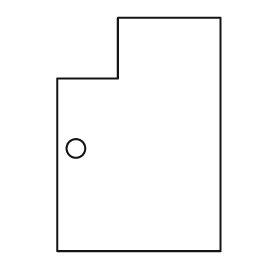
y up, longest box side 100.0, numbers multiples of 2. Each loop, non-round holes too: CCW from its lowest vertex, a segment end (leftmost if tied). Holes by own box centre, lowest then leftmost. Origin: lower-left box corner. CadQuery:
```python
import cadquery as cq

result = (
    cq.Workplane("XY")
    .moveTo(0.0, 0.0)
    .lineTo(70.0, 0.0)
    .lineTo(70.0, 100.0)
    .lineTo(26.0, 100.0)
    .lineTo(26.0, 74.0)
    .lineTo(0.0, 74.0)
    .close()
    .moveTo(8.0, 44.0)
    .circle(4.0)
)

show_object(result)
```